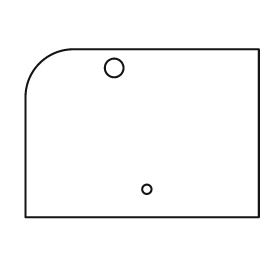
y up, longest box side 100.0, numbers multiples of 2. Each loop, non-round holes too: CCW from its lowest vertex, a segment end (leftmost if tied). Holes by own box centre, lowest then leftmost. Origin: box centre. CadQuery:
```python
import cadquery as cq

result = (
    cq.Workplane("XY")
    .moveTo(-50.0, -36.0)
    .lineTo(50.0, -36.0)
    .lineTo(50.0, 36.0)
    .lineTo(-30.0, 36.0)
    .threePointArc((-44.0, 30.0), (-50.0, 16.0))
    .close()
    .moveTo(2.0, -24.0)
    .circle(2.0)
    .moveTo(-12.0, 28.0)
    .circle(4.0)
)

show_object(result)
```